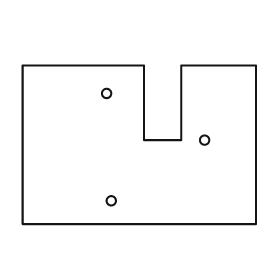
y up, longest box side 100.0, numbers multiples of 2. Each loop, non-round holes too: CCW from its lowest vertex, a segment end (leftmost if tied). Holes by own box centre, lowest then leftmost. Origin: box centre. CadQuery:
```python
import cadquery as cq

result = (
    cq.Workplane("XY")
    .moveTo(-50.0, -34.0)
    .lineTo(50.0, -34.0)
    .lineTo(50.0, 34.0)
    .lineTo(18.0, 34.0)
    .lineTo(18.0, 2.0)
    .lineTo(2.0, 2.0)
    .lineTo(2.0, 34.0)
    .lineTo(-50.0, 34.0)
    .close()
    .moveTo(-12.0, -24.0)
    .circle(2.0)
    .moveTo(28.0, 2.0)
    .circle(2.0)
    .moveTo(-14.0, 22.0)
    .circle(2.0)
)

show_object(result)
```